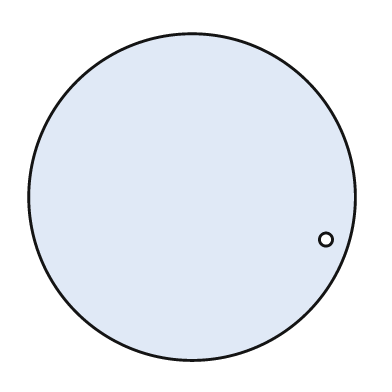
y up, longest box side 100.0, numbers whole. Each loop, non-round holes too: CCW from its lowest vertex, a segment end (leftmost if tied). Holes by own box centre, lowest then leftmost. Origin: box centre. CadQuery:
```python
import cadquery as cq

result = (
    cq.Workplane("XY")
    .moveTo(0.0, 0.0)
    .circle(50.0)
    .moveTo(41.0, -13.0)
    .circle(2.0)
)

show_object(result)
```